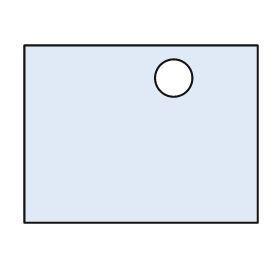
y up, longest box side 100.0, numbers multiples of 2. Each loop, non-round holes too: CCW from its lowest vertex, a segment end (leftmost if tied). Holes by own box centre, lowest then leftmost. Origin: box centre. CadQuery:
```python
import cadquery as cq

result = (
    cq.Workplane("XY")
    .moveTo(-50.0, -38.0)
    .lineTo(50.0, -38.0)
    .lineTo(50.0, 38.0)
    .lineTo(-50.0, 38.0)
    .close()
    .moveTo(14.0, 24.0)
    .circle(8.0)
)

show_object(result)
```